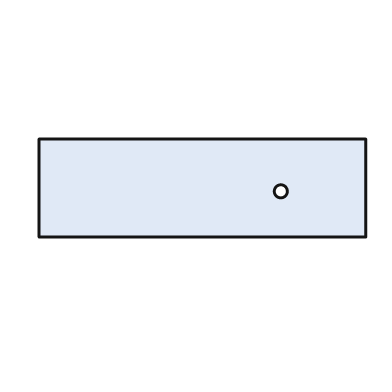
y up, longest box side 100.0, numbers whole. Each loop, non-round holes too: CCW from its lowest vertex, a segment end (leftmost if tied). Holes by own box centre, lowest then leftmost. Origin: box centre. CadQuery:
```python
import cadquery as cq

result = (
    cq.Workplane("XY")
    .moveTo(-50.0, -15.0)
    .lineTo(50.0, -15.0)
    .lineTo(50.0, 15.0)
    .lineTo(-50.0, 15.0)
    .close()
    .moveTo(24.0, -1.0)
    .circle(2.0)
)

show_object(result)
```